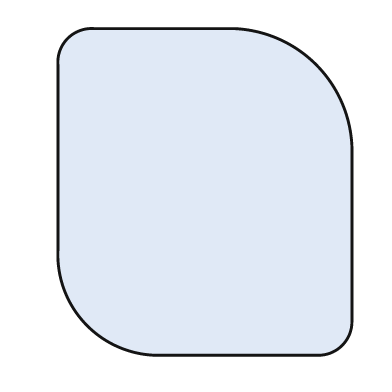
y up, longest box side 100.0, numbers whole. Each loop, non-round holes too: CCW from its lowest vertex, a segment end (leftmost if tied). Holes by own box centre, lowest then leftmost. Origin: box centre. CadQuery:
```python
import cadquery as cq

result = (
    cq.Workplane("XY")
    .moveTo(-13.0, -50.0)
    .lineTo(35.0, -50.0)
    .threePointArc((42.0, -47.0), (45.0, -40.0))
    .lineTo(45.0, 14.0)
    .threePointArc((34.0, 39.0), (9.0, 50.0))
    .lineTo(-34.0, 50.0)
    .threePointArc((-42.0, 47.0), (-45.0, 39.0))
    .lineTo(-45.0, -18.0)
    .threePointArc((-36.0, -41.0), (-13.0, -50.0))
    .close()
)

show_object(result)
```